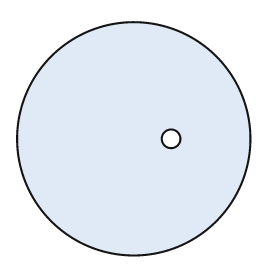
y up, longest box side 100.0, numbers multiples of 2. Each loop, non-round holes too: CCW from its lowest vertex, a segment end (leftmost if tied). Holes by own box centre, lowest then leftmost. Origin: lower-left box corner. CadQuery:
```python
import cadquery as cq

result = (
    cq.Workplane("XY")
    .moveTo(50.0, 50.0)
    .circle(50.0)
    .moveTo(66.0, 50.0)
    .circle(4.0)
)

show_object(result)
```